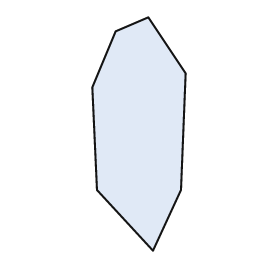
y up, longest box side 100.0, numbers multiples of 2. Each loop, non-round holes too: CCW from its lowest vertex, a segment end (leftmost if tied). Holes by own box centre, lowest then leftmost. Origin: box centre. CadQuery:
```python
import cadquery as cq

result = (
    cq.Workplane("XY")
    .moveTo(6.0, -50.0)
    .lineTo(18.0, -24.0)
    .lineTo(20.0, 26.0)
    .lineTo(4.0, 50.0)
    .lineTo(-10.0, 44.0)
    .lineTo(-20.0, 20.0)
    .lineTo(-18.0, -24.0)
    .close()
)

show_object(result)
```